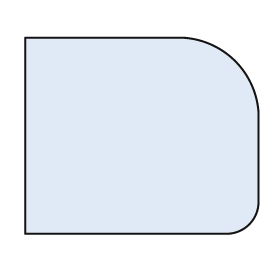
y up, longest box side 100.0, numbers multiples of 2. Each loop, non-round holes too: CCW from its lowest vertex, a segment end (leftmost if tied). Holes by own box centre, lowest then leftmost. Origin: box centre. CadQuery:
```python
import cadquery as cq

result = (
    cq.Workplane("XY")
    .moveTo(-50.0, -42.0)
    .lineTo(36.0, -42.0)
    .threePointArc((46.0, -38.0), (50.0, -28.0))
    .lineTo(50.0, 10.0)
    .threePointArc((40.0, 32.0), (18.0, 42.0))
    .lineTo(-50.0, 42.0)
    .close()
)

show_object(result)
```